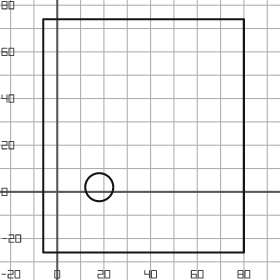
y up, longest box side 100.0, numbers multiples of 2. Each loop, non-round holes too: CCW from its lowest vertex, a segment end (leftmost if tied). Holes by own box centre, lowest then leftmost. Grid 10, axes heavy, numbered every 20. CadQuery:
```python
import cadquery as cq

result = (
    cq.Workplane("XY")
    .moveTo(-6.0, -26.0)
    .lineTo(80.0, -26.0)
    .lineTo(80.0, 74.0)
    .lineTo(-6.0, 74.0)
    .close()
    .moveTo(18.0, 2.0)
    .circle(6.0)
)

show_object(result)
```